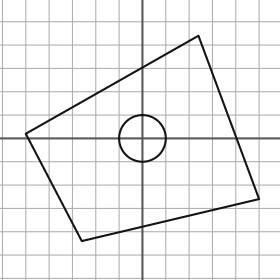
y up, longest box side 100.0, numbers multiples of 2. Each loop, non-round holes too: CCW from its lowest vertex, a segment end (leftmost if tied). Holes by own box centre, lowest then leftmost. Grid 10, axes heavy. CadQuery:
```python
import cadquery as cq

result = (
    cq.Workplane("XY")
    .moveTo(-26.0, -44.0)
    .lineTo(50.0, -26.0)
    .lineTo(24.0, 44.0)
    .lineTo(-50.0, 2.0)
    .close()
    .moveTo(0.0, 0.0)
    .circle(10.0)
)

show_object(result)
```